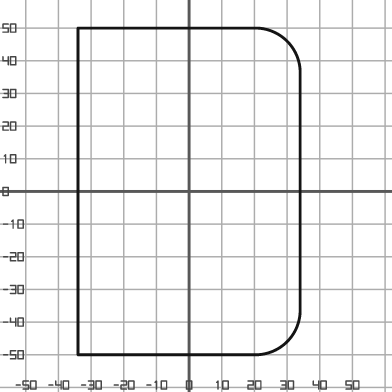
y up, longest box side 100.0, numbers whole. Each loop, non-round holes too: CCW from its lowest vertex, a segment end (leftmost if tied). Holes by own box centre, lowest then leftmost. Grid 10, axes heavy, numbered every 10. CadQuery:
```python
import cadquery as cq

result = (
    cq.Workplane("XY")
    .moveTo(-34.0, -50.0)
    .lineTo(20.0, -50.0)
    .threePointArc((30.0, -46.0), (34.0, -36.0))
    .lineTo(34.0, 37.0)
    .threePointArc((30.0, 46.0), (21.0, 50.0))
    .lineTo(-34.0, 50.0)
    .close()
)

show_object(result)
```